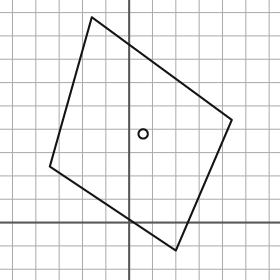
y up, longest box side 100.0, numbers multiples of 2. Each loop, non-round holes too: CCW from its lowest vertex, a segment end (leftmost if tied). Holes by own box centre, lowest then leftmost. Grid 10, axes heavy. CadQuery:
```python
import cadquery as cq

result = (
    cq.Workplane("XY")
    .moveTo(20.0, -12.0)
    .lineTo(44.0, 44.0)
    .lineTo(-16.0, 88.0)
    .lineTo(-34.0, 24.0)
    .close()
    .moveTo(6.0, 38.0)
    .circle(2.0)
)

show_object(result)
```